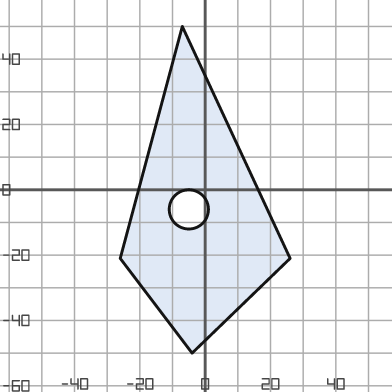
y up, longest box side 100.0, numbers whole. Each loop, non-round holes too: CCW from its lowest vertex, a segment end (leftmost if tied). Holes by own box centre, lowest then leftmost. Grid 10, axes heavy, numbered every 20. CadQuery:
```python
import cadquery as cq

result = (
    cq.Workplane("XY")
    .moveTo(-4.0, -50.0)
    .lineTo(26.0, -21.0)
    .lineTo(-7.0, 50.0)
    .lineTo(-26.0, -21.0)
    .close()
    .moveTo(-5.0, -6.0)
    .circle(6.0)
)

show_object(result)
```